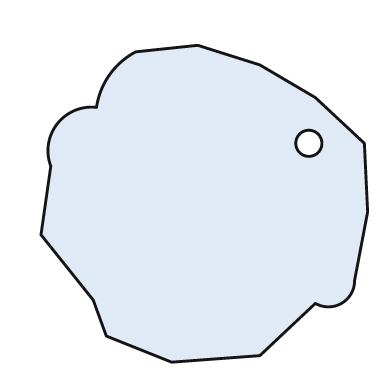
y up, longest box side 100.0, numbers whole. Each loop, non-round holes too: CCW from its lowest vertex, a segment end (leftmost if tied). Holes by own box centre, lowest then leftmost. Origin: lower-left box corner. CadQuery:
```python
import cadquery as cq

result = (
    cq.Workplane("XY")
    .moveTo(40.0, 0.0)
    .lineTo(67.0, 2.0)
    .lineTo(84.0, 18.0)
    .threePointArc((92.0, 18.0), (96.0, 25.0))
    .lineTo(100.0, 46.0)
    .lineTo(99.0, 67.0)
    .lineTo(84.0, 81.0)
    .lineTo(67.0, 91.0)
    .lineTo(48.0, 97.0)
    .lineTo(29.0, 95.0)
    .threePointArc((21.0, 88.0), (17.0, 78.0))
    .threePointArc((5.0, 73.0), (3.0, 60.0))
    .lineTo(0.0, 39.0)
    .lineTo(16.0, 19.0)
    .lineTo(20.0, 8.0)
    .close()
    .moveTo(82.0, 67.0)
    .circle(4.0)
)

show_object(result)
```